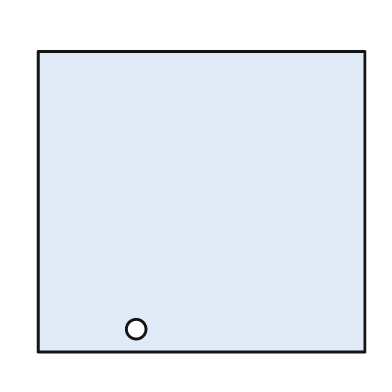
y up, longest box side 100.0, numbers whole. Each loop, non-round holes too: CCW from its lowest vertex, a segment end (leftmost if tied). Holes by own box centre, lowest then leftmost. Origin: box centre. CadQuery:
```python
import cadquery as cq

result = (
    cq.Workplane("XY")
    .moveTo(-50.0, -46.0)
    .lineTo(50.0, -46.0)
    .lineTo(50.0, 46.0)
    .lineTo(-50.0, 46.0)
    .close()
    .moveTo(-20.0, -39.0)
    .circle(3.0)
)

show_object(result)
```